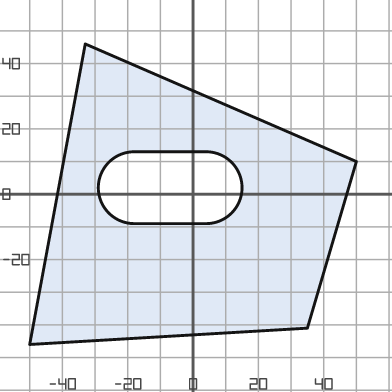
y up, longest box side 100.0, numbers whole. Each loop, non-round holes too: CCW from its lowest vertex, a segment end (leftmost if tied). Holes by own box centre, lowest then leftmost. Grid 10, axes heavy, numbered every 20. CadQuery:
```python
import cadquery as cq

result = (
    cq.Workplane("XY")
    .moveTo(-50.0, -46.0)
    .lineTo(35.0, -41.0)
    .lineTo(50.0, 10.0)
    .lineTo(-33.0, 46.0)
    .close()
    .moveTo(-18.0, -9.0)
    .lineTo(4.0, -9.0)
    .threePointArc((15.0, 2.0), (4.0, 13.0))
    .lineTo(-18.0, 13.0)
    .threePointArc((-29.0, 2.0), (-18.0, -9.0))
    .close()
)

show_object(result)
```